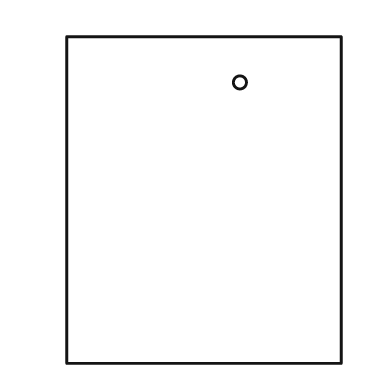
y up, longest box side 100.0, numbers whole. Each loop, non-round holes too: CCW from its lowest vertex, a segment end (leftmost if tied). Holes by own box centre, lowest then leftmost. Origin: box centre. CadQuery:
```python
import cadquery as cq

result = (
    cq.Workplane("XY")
    .moveTo(-42.0, -50.0)
    .lineTo(42.0, -50.0)
    .lineTo(42.0, 50.0)
    .lineTo(-42.0, 50.0)
    .close()
    .moveTo(11.0, 36.0)
    .circle(2.0)
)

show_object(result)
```